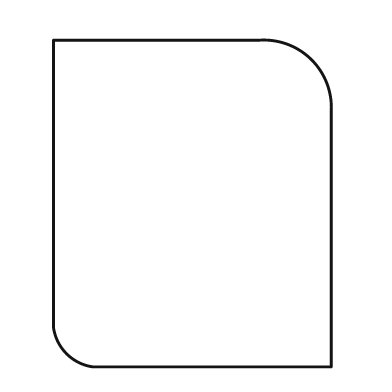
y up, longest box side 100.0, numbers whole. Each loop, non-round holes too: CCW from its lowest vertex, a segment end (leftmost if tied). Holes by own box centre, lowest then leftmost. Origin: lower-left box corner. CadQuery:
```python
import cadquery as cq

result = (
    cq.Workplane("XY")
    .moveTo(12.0, 0.0)
    .lineTo(85.0, 0.0)
    .lineTo(85.0, 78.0)
    .threePointArc((79.0, 94.0), (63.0, 100.0))
    .lineTo(0.0, 100.0)
    .lineTo(0.0, 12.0)
    .threePointArc((4.0, 4.0), (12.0, 0.0))
    .close()
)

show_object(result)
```